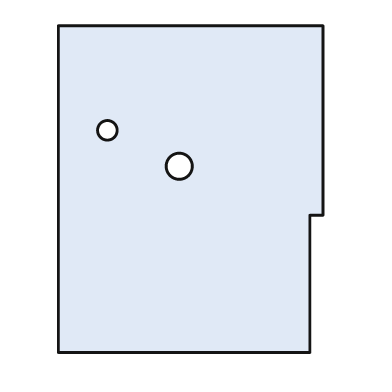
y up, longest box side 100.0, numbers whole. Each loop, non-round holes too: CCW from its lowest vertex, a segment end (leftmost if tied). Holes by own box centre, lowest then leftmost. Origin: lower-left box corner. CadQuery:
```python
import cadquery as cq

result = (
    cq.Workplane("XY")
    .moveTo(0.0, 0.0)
    .lineTo(77.0, 0.0)
    .lineTo(77.0, 42.0)
    .lineTo(81.0, 42.0)
    .lineTo(81.0, 100.0)
    .lineTo(0.0, 100.0)
    .close()
    .moveTo(37.0, 57.0)
    .circle(4.0)
    .moveTo(15.0, 68.0)
    .circle(3.0)
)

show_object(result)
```